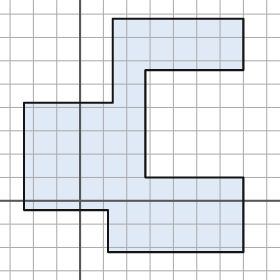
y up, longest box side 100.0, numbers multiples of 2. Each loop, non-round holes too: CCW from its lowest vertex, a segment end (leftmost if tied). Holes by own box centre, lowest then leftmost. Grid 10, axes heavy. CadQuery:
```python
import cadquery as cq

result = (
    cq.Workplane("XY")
    .moveTo(12.0, -22.0)
    .lineTo(70.0, -22.0)
    .lineTo(70.0, 10.0)
    .lineTo(28.0, 10.0)
    .lineTo(28.0, 56.0)
    .lineTo(70.0, 56.0)
    .lineTo(70.0, 78.0)
    .lineTo(14.0, 78.0)
    .lineTo(14.0, 42.0)
    .lineTo(-24.0, 42.0)
    .lineTo(-24.0, -4.0)
    .lineTo(12.0, -4.0)
    .close()
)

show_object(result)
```